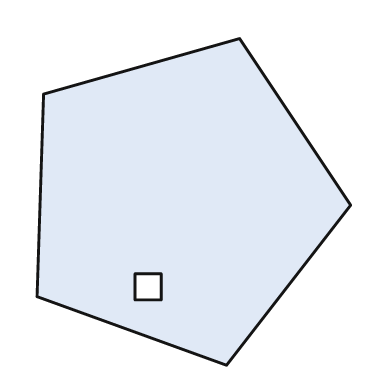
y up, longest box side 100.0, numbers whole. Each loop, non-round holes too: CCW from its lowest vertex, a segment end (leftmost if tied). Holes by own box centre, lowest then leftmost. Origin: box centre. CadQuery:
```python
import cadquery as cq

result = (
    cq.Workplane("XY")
    .moveTo(10.0, -50.0)
    .lineTo(48.0, -1.0)
    .lineTo(14.0, 50.0)
    .lineTo(-46.0, 33.0)
    .lineTo(-48.0, -29.0)
    .close()
    .moveTo(-18.0, -30.0)
    .lineTo(-10.0, -30.0)
    .lineTo(-10.0, -22.0)
    .lineTo(-18.0, -22.0)
    .close()
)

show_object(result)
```